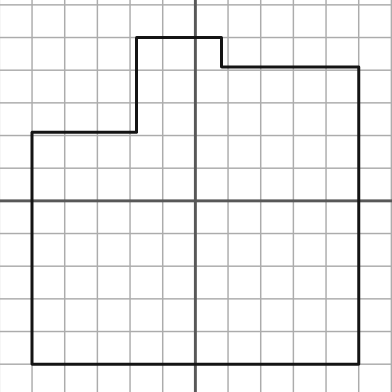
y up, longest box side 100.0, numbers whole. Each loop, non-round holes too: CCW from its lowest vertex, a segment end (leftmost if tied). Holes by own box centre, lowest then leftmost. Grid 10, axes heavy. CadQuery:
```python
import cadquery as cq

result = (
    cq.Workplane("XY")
    .moveTo(-50.0, -50.0)
    .lineTo(50.0, -50.0)
    .lineTo(50.0, 41.0)
    .lineTo(8.0, 41.0)
    .lineTo(8.0, 50.0)
    .lineTo(-18.0, 50.0)
    .lineTo(-18.0, 21.0)
    .lineTo(-50.0, 21.0)
    .close()
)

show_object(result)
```